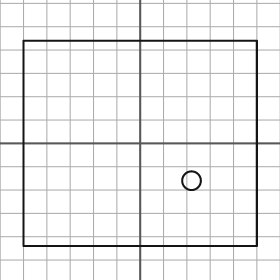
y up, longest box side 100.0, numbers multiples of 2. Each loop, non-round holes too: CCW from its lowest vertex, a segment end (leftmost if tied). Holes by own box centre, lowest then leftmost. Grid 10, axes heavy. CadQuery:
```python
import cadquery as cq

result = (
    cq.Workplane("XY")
    .moveTo(-50.0, -44.0)
    .lineTo(50.0, -44.0)
    .lineTo(50.0, 44.0)
    .lineTo(-50.0, 44.0)
    .close()
    .moveTo(22.0, -16.0)
    .circle(4.0)
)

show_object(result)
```